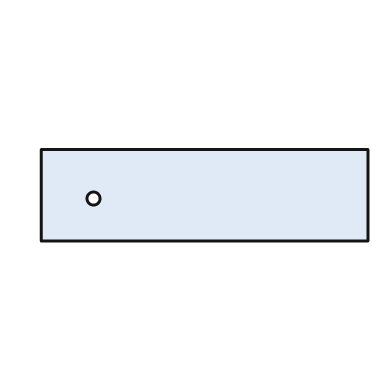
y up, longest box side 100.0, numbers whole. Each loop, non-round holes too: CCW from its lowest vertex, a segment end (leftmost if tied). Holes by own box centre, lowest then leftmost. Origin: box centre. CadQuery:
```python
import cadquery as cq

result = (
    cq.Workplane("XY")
    .moveTo(-50.0, -14.0)
    .lineTo(50.0, -14.0)
    .lineTo(50.0, 14.0)
    .lineTo(-50.0, 14.0)
    .close()
    .moveTo(-34.0, -1.0)
    .circle(2.0)
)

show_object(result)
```